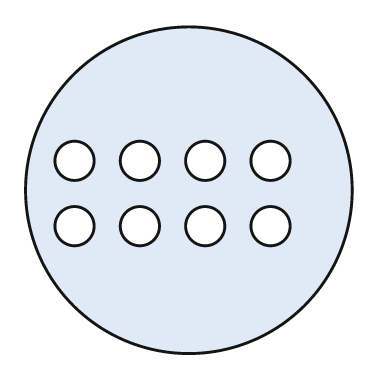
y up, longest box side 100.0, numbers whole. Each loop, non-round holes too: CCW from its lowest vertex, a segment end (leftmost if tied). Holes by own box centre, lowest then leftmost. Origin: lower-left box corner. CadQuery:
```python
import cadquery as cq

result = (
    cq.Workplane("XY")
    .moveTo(50.0, 50.0)
    .circle(50.0)
    .moveTo(15.0, 39.0)
    .circle(6.0)
    .moveTo(35.0, 39.0)
    .circle(6.0)
    .moveTo(55.0, 39.0)
    .circle(6.0)
    .moveTo(75.0, 39.0)
    .circle(6.0)
    .moveTo(15.0, 59.0)
    .circle(6.0)
    .moveTo(35.0, 59.0)
    .circle(6.0)
    .moveTo(55.0, 59.0)
    .circle(6.0)
    .moveTo(75.0, 59.0)
    .circle(6.0)
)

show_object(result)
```